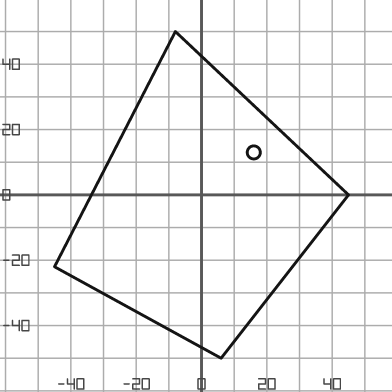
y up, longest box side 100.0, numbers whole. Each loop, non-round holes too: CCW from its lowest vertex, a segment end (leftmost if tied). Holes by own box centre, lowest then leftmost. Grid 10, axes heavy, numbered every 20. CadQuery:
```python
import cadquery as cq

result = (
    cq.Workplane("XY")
    .moveTo(6.0, -50.0)
    .lineTo(45.0, 0.0)
    .lineTo(-8.0, 50.0)
    .lineTo(-45.0, -22.0)
    .close()
    .moveTo(16.0, 13.0)
    .circle(2.0)
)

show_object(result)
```